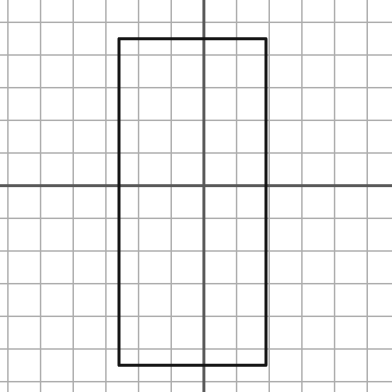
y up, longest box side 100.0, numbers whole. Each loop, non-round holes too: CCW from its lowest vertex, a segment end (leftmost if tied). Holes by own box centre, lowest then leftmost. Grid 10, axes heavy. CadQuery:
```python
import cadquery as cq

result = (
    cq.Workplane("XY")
    .moveTo(-26.0, -55.0)
    .lineTo(19.0, -55.0)
    .lineTo(19.0, 45.0)
    .lineTo(-26.0, 45.0)
    .close()
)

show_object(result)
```